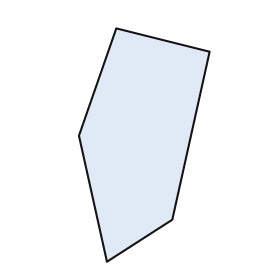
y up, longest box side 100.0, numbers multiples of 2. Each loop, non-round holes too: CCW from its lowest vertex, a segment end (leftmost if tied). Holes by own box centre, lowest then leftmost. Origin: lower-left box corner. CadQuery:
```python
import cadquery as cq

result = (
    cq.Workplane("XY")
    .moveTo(12.0, 0.0)
    .lineTo(40.0, 18.0)
    .lineTo(56.0, 90.0)
    .lineTo(16.0, 100.0)
    .lineTo(0.0, 54.0)
    .close()
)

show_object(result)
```